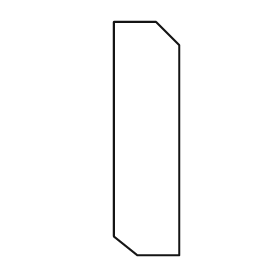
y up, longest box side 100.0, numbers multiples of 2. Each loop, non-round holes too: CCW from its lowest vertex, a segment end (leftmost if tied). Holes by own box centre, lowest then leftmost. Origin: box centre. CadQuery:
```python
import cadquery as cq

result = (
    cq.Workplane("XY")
    .moveTo(-4.0, -50.0)
    .lineTo(14.0, -50.0)
    .lineTo(14.0, 40.0)
    .lineTo(4.0, 50.0)
    .lineTo(-14.0, 50.0)
    .lineTo(-14.0, -42.0)
    .close()
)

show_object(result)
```